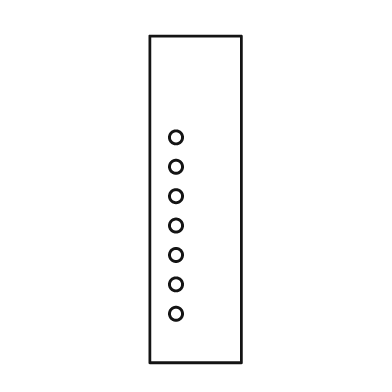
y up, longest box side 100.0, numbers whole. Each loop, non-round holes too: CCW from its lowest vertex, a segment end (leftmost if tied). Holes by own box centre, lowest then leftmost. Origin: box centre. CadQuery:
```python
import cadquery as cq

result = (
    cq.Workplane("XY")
    .moveTo(-14.0, -50.0)
    .lineTo(14.0, -50.0)
    .lineTo(14.0, 50.0)
    .lineTo(-14.0, 50.0)
    .close()
    .moveTo(-6.0, -35.0)
    .circle(2.0)
    .moveTo(-6.0, -26.0)
    .circle(2.0)
    .moveTo(-6.0, -17.0)
    .circle(2.0)
    .moveTo(-6.0, -8.0)
    .circle(2.0)
    .moveTo(-6.0, 1.0)
    .circle(2.0)
    .moveTo(-6.0, 10.0)
    .circle(2.0)
    .moveTo(-6.0, 19.0)
    .circle(2.0)
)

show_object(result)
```